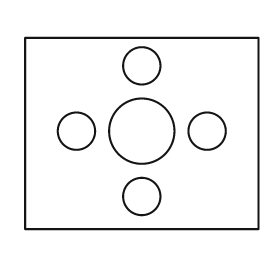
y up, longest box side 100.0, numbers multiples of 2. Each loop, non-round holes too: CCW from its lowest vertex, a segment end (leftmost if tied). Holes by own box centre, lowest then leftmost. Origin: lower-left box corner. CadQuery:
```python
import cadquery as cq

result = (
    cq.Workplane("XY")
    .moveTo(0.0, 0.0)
    .lineTo(100.0, 0.0)
    .lineTo(100.0, 82.0)
    .lineTo(0.0, 82.0)
    .close()
    .moveTo(50.0, 14.0)
    .circle(8.0)
    .moveTo(22.0, 42.0)
    .circle(8.0)
    .moveTo(50.0, 42.0)
    .circle(14.0)
    .moveTo(78.0, 42.0)
    .circle(8.0)
    .moveTo(50.0, 70.0)
    .circle(8.0)
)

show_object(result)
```